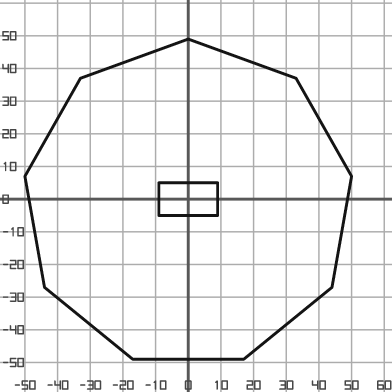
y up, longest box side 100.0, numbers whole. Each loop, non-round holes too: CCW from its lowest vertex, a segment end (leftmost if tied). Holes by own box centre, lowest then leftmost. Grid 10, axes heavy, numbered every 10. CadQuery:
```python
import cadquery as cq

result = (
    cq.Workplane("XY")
    .moveTo(-17.0, -49.0)
    .lineTo(17.0, -49.0)
    .lineTo(44.0, -27.0)
    .lineTo(50.0, 7.0)
    .lineTo(33.0, 37.0)
    .lineTo(0.0, 49.0)
    .lineTo(-33.0, 37.0)
    .lineTo(-50.0, 7.0)
    .lineTo(-44.0, -27.0)
    .close()
    .moveTo(-9.0, -5.0)
    .lineTo(9.0, -5.0)
    .lineTo(9.0, 5.0)
    .lineTo(-9.0, 5.0)
    .close()
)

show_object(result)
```